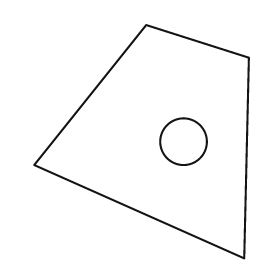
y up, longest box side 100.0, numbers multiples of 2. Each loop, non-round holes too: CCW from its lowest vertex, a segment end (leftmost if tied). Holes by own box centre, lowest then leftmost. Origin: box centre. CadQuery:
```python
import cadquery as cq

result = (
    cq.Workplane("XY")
    .moveTo(44.0, -50.0)
    .lineTo(46.0, 36.0)
    .lineTo(2.0, 50.0)
    .lineTo(-46.0, -10.0)
    .close()
    .moveTo(18.0, 0.0)
    .circle(10.0)
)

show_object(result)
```